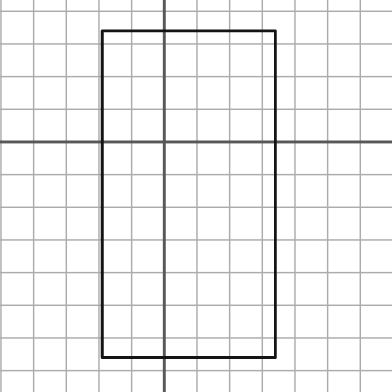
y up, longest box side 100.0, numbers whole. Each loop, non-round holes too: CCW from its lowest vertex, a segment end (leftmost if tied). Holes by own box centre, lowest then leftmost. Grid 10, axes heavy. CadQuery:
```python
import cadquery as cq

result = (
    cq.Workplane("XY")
    .moveTo(-19.0, -66.0)
    .lineTo(34.0, -66.0)
    .lineTo(34.0, 34.0)
    .lineTo(-19.0, 34.0)
    .close()
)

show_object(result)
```